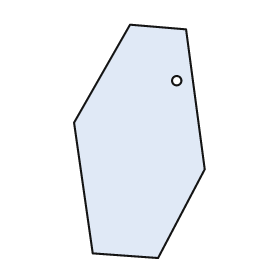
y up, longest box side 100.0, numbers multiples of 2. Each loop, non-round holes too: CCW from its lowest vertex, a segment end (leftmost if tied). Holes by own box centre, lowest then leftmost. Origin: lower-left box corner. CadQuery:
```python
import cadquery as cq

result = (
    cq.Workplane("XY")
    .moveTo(36.0, 0.0)
    .lineTo(56.0, 38.0)
    .lineTo(48.0, 98.0)
    .lineTo(24.0, 100.0)
    .lineTo(0.0, 58.0)
    .lineTo(8.0, 2.0)
    .close()
    .moveTo(44.0, 76.0)
    .circle(2.0)
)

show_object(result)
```